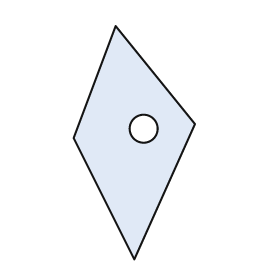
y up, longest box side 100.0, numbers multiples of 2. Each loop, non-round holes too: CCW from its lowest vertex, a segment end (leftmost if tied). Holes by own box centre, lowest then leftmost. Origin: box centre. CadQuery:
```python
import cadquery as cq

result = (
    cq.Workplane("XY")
    .moveTo(0.0, -50.0)
    .lineTo(26.0, 8.0)
    .lineTo(-8.0, 50.0)
    .lineTo(-26.0, 2.0)
    .close()
    .moveTo(4.0, 6.0)
    .circle(6.0)
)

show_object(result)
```